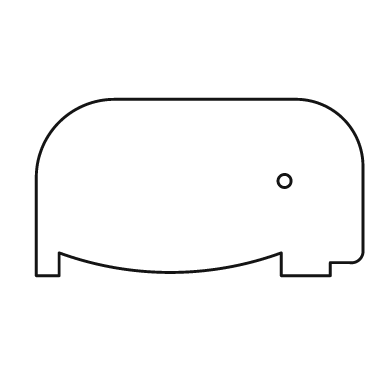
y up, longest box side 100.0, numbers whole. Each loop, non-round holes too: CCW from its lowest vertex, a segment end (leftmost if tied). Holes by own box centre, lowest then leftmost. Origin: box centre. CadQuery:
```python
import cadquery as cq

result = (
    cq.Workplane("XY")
    .moveTo(-50.0, -27.0)
    .lineTo(-43.0, -27.0)
    .lineTo(-43.0, -20.0)
    .threePointArc((-9.0, -26.0), (25.0, -20.0))
    .lineTo(25.0, -27.0)
    .lineTo(40.0, -27.0)
    .lineTo(40.0, -23.0)
    .lineTo(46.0, -23.0)
    .threePointArc((49.0, -22.0), (50.0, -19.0))
    .lineTo(50.0, 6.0)
    .threePointArc((44.0, 21.0), (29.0, 27.0))
    .lineTo(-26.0, 27.0)
    .threePointArc((-43.0, 20.0), (-50.0, 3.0))
    .close()
    .moveTo(26.0, 2.0)
    .circle(2.0)
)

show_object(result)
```